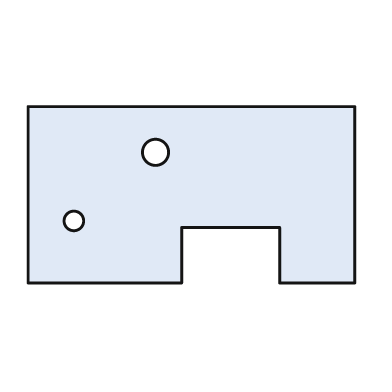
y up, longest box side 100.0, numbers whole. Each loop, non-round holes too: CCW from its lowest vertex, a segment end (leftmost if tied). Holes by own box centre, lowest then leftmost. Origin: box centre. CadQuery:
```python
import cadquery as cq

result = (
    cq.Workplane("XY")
    .moveTo(-50.0, -27.0)
    .lineTo(-3.0, -27.0)
    .lineTo(-3.0, -10.0)
    .lineTo(27.0, -10.0)
    .lineTo(27.0, -27.0)
    .lineTo(50.0, -27.0)
    .lineTo(50.0, 27.0)
    .lineTo(-50.0, 27.0)
    .close()
    .moveTo(-36.0, -8.0)
    .circle(3.0)
    .moveTo(-11.0, 13.0)
    .circle(4.0)
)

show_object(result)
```